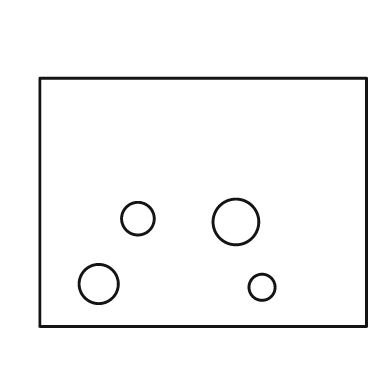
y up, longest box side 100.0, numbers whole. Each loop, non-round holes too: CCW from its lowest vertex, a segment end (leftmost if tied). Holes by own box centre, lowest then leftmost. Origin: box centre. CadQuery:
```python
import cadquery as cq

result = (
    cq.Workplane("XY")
    .moveTo(-50.0, -38.0)
    .lineTo(50.0, -38.0)
    .lineTo(50.0, 38.0)
    .lineTo(-50.0, 38.0)
    .close()
    .moveTo(18.0, -26.0)
    .circle(4.0)
    .moveTo(-32.0, -25.0)
    .circle(6.0)
    .moveTo(10.0, -6.0)
    .circle(7.0)
    .moveTo(-20.0, -5.0)
    .circle(5.0)
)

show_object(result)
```